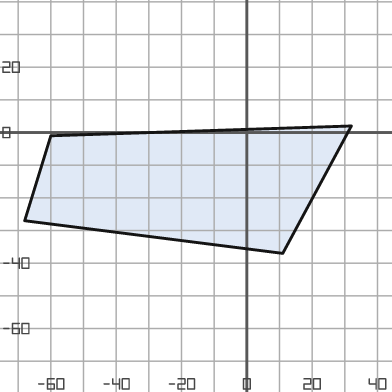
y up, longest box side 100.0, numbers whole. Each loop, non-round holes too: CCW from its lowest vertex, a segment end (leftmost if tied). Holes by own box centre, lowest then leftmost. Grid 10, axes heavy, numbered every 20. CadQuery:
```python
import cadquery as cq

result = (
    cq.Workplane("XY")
    .moveTo(11.0, -37.0)
    .lineTo(32.0, 2.0)
    .lineTo(-60.0, -1.0)
    .lineTo(-68.0, -27.0)
    .close()
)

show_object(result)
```